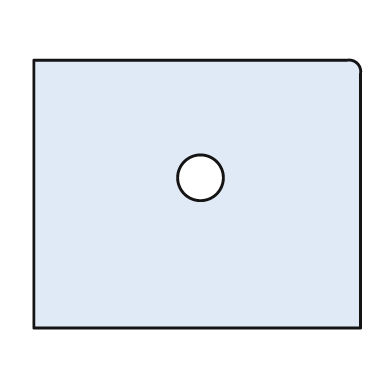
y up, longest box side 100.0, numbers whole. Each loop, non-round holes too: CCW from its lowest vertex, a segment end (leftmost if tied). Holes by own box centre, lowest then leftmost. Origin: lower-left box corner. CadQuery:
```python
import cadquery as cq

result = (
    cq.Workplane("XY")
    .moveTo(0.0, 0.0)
    .lineTo(100.0, 0.0)
    .lineTo(100.0, 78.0)
    .threePointArc((99.0, 81.0), (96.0, 82.0))
    .lineTo(0.0, 82.0)
    .close()
    .moveTo(51.0, 46.0)
    .circle(7.0)
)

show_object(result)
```